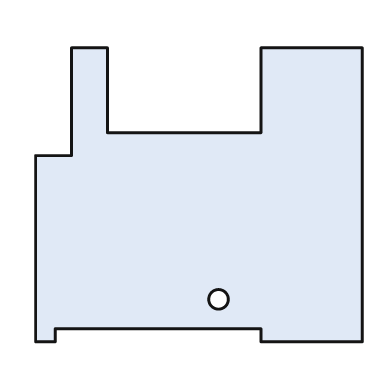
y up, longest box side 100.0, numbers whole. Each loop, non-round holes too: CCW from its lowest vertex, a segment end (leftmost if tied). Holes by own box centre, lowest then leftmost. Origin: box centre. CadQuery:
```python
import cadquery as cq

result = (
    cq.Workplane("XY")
    .moveTo(-50.0, -45.0)
    .lineTo(-44.0, -45.0)
    .lineTo(-44.0, -41.0)
    .lineTo(19.0, -41.0)
    .lineTo(19.0, -45.0)
    .lineTo(50.0, -45.0)
    .lineTo(50.0, 45.0)
    .lineTo(19.0, 45.0)
    .lineTo(19.0, 19.0)
    .lineTo(-28.0, 19.0)
    .lineTo(-28.0, 45.0)
    .lineTo(-39.0, 45.0)
    .lineTo(-39.0, 12.0)
    .lineTo(-50.0, 12.0)
    .close()
    .moveTo(6.0, -32.0)
    .circle(3.0)
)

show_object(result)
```